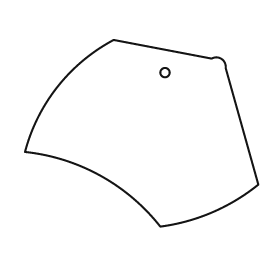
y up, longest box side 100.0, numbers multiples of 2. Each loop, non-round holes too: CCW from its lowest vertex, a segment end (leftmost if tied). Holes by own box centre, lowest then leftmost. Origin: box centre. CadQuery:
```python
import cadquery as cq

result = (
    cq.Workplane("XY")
    .moveTo(8.0, -40.0)
    .threePointArc((30.0, -34.0), (50.0, -22.0))
    .lineTo(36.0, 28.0)
    .threePointArc((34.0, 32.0), (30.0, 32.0))
    .lineTo(-12.0, 40.0)
    .threePointArc((-36.0, 20.0), (-50.0, -8.0))
    .threePointArc((-18.0, -18.0), (8.0, -40.0))
    .close()
    .moveTo(10.0, 26.0)
    .circle(2.0)
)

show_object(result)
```